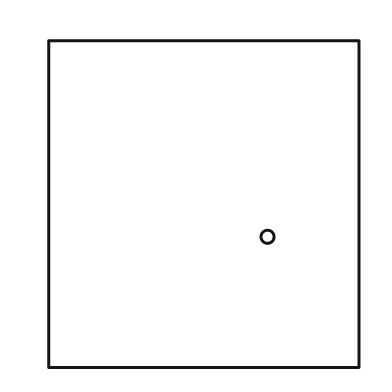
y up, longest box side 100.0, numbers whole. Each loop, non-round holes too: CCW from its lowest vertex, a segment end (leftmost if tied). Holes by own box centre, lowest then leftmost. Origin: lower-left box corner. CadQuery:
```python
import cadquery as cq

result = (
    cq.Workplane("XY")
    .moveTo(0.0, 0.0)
    .lineTo(95.0, 0.0)
    .lineTo(95.0, 100.0)
    .lineTo(0.0, 100.0)
    .close()
    .moveTo(67.0, 40.0)
    .circle(2.0)
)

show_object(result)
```